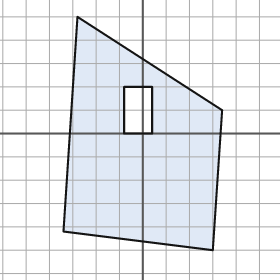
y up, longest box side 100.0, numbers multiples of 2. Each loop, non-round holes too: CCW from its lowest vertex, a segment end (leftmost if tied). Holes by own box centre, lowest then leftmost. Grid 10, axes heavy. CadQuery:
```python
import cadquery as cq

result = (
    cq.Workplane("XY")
    .moveTo(30.0, -50.0)
    .lineTo(34.0, 10.0)
    .lineTo(-28.0, 50.0)
    .lineTo(-34.0, -42.0)
    .close()
    .moveTo(-8.0, 0.0)
    .lineTo(4.0, 0.0)
    .lineTo(4.0, 20.0)
    .lineTo(-8.0, 20.0)
    .close()
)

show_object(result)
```